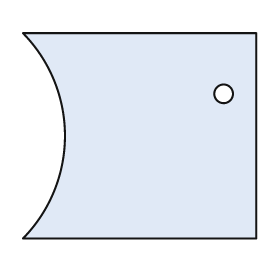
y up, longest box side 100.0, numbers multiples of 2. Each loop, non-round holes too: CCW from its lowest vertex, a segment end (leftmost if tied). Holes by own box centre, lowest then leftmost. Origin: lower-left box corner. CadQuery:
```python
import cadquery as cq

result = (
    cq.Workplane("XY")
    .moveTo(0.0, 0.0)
    .lineTo(100.0, 0.0)
    .lineTo(100.0, 88.0)
    .lineTo(0.0, 88.0)
    .threePointArc((18.0, 44.0), (0.0, 0.0))
    .close()
    .moveTo(86.0, 62.0)
    .circle(4.0)
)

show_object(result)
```